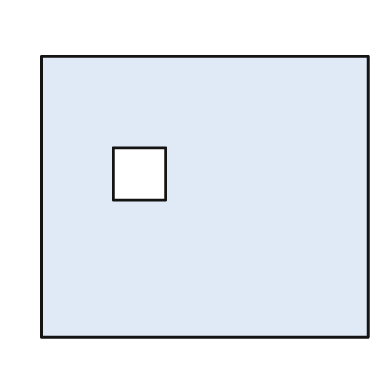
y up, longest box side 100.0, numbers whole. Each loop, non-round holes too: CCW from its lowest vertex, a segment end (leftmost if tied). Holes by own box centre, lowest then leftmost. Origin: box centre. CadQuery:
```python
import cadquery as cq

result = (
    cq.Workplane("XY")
    .moveTo(-50.0, -43.0)
    .lineTo(50.0, -43.0)
    .lineTo(50.0, 43.0)
    .lineTo(-50.0, 43.0)
    .close()
    .moveTo(-28.0, -1.0)
    .lineTo(-12.0, -1.0)
    .lineTo(-12.0, 15.0)
    .lineTo(-28.0, 15.0)
    .close()
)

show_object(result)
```